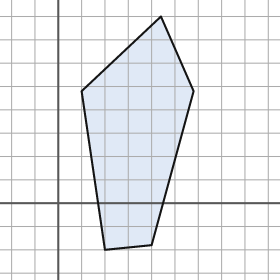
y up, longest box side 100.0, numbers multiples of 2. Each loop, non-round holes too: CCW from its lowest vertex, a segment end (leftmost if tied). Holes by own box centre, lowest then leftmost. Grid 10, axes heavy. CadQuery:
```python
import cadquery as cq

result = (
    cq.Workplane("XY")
    .moveTo(20.0, -20.0)
    .lineTo(40.0, -18.0)
    .lineTo(58.0, 48.0)
    .lineTo(44.0, 80.0)
    .lineTo(10.0, 48.0)
    .close()
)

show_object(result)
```